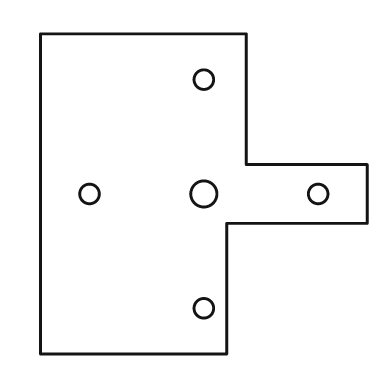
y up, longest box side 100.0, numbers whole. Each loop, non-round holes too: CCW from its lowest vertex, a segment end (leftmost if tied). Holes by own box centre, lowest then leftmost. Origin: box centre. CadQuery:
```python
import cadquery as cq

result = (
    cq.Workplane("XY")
    .moveTo(-50.0, -49.0)
    .lineTo(7.0, -49.0)
    .lineTo(7.0, -9.0)
    .lineTo(50.0, -9.0)
    .lineTo(50.0, 9.0)
    .lineTo(13.0, 9.0)
    .lineTo(13.0, 49.0)
    .lineTo(-50.0, 49.0)
    .close()
    .moveTo(0.0, -35.0)
    .circle(3.0)
    .moveTo(-35.0, 0.0)
    .circle(3.0)
    .moveTo(0.0, 0.0)
    .circle(4.0)
    .moveTo(35.0, 0.0)
    .circle(3.0)
    .moveTo(0.0, 35.0)
    .circle(3.0)
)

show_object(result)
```